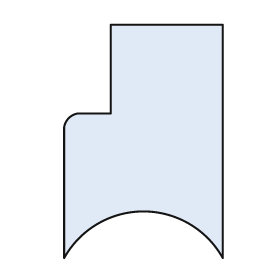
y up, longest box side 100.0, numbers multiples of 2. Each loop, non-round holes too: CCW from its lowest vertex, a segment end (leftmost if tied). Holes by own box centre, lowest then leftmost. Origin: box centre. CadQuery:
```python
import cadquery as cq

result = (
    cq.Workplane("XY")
    .moveTo(-34.0, -50.0)
    .threePointArc((0.0, -30.0), (34.0, -50.0))
    .lineTo(34.0, 50.0)
    .lineTo(-14.0, 50.0)
    .lineTo(-14.0, 12.0)
    .lineTo(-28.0, 12.0)
    .threePointArc((-32.0, 10.0), (-34.0, 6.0))
    .close()
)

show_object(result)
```